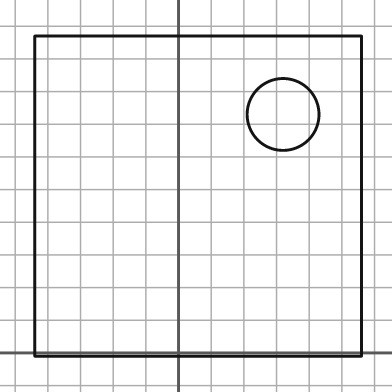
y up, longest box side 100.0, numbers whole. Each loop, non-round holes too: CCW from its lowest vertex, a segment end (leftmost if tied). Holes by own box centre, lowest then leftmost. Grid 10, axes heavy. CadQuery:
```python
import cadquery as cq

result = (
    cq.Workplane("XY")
    .moveTo(-44.0, -1.0)
    .lineTo(56.0, -1.0)
    .lineTo(56.0, 97.0)
    .lineTo(-44.0, 97.0)
    .close()
    .moveTo(32.0, 73.0)
    .circle(11.0)
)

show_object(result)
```